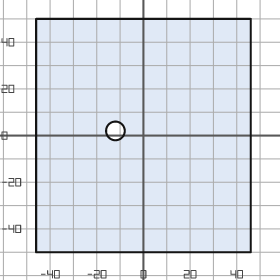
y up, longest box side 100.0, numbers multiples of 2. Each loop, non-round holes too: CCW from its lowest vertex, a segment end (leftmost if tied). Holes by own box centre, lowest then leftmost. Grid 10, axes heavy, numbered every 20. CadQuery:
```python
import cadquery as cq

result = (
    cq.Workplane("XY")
    .moveTo(-46.0, -50.0)
    .lineTo(46.0, -50.0)
    .lineTo(46.0, 50.0)
    .lineTo(-46.0, 50.0)
    .close()
    .moveTo(-12.0, 2.0)
    .circle(4.0)
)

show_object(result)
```